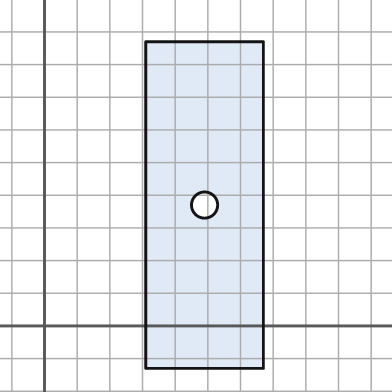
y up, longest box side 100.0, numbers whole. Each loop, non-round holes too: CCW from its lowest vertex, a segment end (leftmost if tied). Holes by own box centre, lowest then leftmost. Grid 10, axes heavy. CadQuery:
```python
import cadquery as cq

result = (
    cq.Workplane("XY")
    .moveTo(31.0, -13.0)
    .lineTo(67.0, -13.0)
    .lineTo(67.0, 87.0)
    .lineTo(31.0, 87.0)
    .close()
    .moveTo(49.0, 37.0)
    .circle(4.0)
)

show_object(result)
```